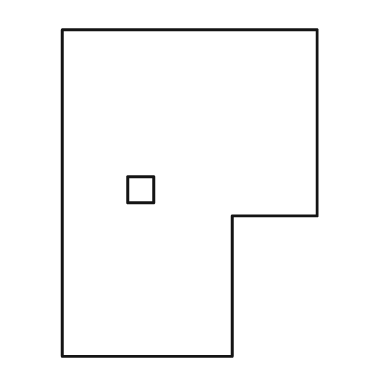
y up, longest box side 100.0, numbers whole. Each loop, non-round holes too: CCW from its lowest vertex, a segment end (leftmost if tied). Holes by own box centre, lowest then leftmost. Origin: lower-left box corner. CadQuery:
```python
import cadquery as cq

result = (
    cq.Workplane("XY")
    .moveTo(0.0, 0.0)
    .lineTo(52.0, 0.0)
    .lineTo(52.0, 43.0)
    .lineTo(78.0, 43.0)
    .lineTo(78.0, 100.0)
    .lineTo(0.0, 100.0)
    .close()
    .moveTo(20.0, 47.0)
    .lineTo(28.0, 47.0)
    .lineTo(28.0, 55.0)
    .lineTo(20.0, 55.0)
    .close()
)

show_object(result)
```